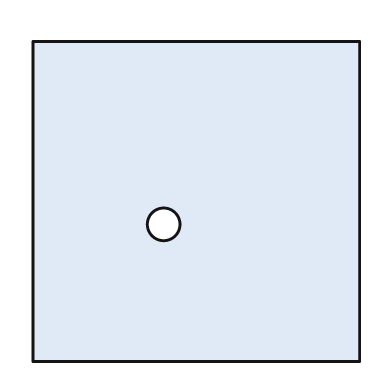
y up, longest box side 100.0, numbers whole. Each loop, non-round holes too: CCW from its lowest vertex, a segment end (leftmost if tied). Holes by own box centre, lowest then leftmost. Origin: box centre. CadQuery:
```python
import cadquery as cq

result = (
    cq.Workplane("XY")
    .moveTo(-50.0, -49.0)
    .lineTo(50.0, -49.0)
    .lineTo(50.0, 49.0)
    .lineTo(-50.0, 49.0)
    .close()
    .moveTo(-10.0, -7.0)
    .circle(5.0)
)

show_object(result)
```